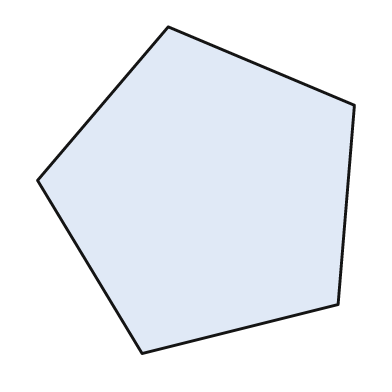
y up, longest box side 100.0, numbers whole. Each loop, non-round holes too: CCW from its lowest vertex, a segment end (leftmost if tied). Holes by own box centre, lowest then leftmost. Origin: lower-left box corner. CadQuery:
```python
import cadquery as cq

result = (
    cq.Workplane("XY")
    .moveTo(32.0, 0.0)
    .lineTo(92.0, 15.0)
    .lineTo(97.0, 76.0)
    .lineTo(40.0, 100.0)
    .lineTo(0.0, 53.0)
    .close()
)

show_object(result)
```